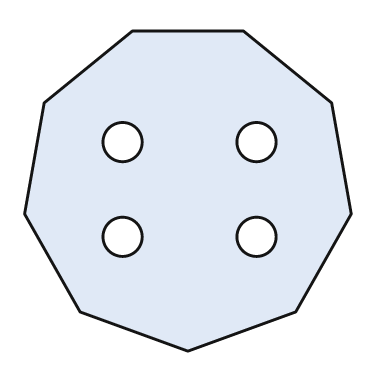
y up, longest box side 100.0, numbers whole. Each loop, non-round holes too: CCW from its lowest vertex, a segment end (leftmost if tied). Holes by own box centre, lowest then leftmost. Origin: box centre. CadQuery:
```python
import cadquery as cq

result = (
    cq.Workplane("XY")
    .moveTo(0.0, -49.0)
    .lineTo(33.0, -37.0)
    .lineTo(50.0, -7.0)
    .lineTo(44.0, 27.0)
    .lineTo(17.0, 49.0)
    .lineTo(-17.0, 49.0)
    .lineTo(-44.0, 27.0)
    .lineTo(-50.0, -7.0)
    .lineTo(-33.0, -37.0)
    .close()
    .moveTo(-20.0, -14.0)
    .circle(6.0)
    .moveTo(21.0, -14.0)
    .circle(6.0)
    .moveTo(-20.0, 15.0)
    .circle(6.0)
    .moveTo(21.0, 15.0)
    .circle(6.0)
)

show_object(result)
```